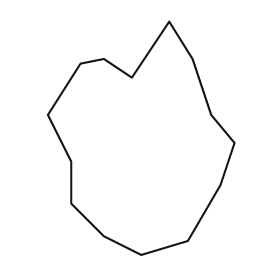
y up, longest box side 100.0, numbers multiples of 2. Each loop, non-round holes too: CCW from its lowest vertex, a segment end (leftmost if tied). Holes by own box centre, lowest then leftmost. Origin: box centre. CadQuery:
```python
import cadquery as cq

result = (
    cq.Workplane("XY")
    .moveTo(0.0, -50.0)
    .lineTo(20.0, -44.0)
    .lineTo(34.0, -20.0)
    .lineTo(40.0, -2.0)
    .lineTo(30.0, 10.0)
    .lineTo(22.0, 34.0)
    .lineTo(12.0, 50.0)
    .lineTo(-4.0, 26.0)
    .lineTo(-16.0, 34.0)
    .lineTo(-26.0, 32.0)
    .lineTo(-40.0, 10.0)
    .lineTo(-30.0, -10.0)
    .lineTo(-30.0, -28.0)
    .lineTo(-16.0, -42.0)
    .close()
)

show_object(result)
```